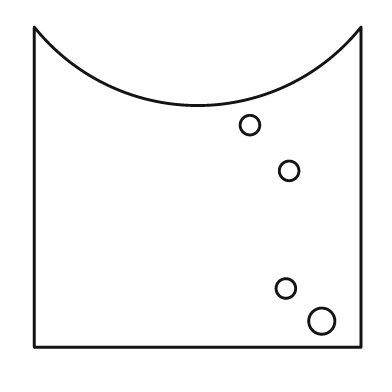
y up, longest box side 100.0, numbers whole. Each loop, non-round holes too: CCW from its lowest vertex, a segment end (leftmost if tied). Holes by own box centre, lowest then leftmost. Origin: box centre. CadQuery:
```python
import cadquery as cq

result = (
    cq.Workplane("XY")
    .moveTo(-50.0, -49.0)
    .lineTo(50.0, -49.0)
    .lineTo(50.0, 49.0)
    .threePointArc((0.0, 25.0), (-50.0, 49.0))
    .close()
    .moveTo(38.0, -41.0)
    .circle(4.0)
    .moveTo(27.0, -31.0)
    .circle(3.0)
    .moveTo(28.0, 5.0)
    .circle(3.0)
    .moveTo(16.0, 19.0)
    .circle(3.0)
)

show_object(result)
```